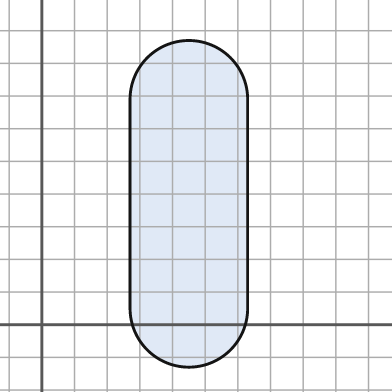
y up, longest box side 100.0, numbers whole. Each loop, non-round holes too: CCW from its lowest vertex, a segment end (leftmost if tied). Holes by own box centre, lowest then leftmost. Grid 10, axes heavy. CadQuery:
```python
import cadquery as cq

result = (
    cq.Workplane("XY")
    .moveTo(27.0, 5.0)
    .threePointArc((45.0, -13.0), (63.0, 5.0))
    .lineTo(63.0, 69.0)
    .threePointArc((45.0, 87.0), (27.0, 69.0))
    .close()
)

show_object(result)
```